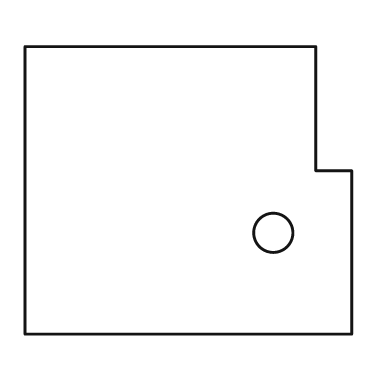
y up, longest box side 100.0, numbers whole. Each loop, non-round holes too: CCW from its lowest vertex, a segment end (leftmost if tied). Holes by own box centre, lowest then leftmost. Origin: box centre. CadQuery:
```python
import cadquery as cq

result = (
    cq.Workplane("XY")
    .moveTo(-50.0, -44.0)
    .lineTo(50.0, -44.0)
    .lineTo(50.0, 6.0)
    .lineTo(39.0, 6.0)
    .lineTo(39.0, 44.0)
    .lineTo(-50.0, 44.0)
    .close()
    .moveTo(26.0, -13.0)
    .circle(6.0)
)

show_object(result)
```